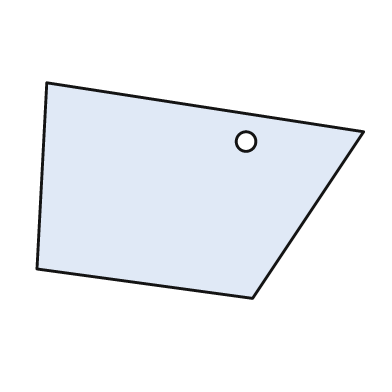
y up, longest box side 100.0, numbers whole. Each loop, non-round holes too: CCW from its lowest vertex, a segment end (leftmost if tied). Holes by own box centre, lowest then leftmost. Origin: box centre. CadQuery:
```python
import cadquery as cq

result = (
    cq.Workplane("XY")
    .moveTo(16.0, -33.0)
    .lineTo(50.0, 18.0)
    .lineTo(-47.0, 33.0)
    .lineTo(-50.0, -24.0)
    .close()
    .moveTo(14.0, 15.0)
    .circle(3.0)
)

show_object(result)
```